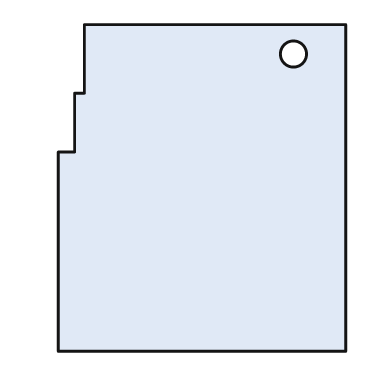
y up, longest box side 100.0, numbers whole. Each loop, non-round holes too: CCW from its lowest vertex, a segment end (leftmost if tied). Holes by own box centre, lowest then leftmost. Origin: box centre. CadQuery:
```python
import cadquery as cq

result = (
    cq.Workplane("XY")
    .moveTo(-44.0, -50.0)
    .lineTo(44.0, -50.0)
    .lineTo(44.0, 50.0)
    .lineTo(-36.0, 50.0)
    .lineTo(-36.0, 29.0)
    .lineTo(-39.0, 29.0)
    .lineTo(-39.0, 11.0)
    .lineTo(-44.0, 11.0)
    .close()
    .moveTo(28.0, 41.0)
    .circle(4.0)
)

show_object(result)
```